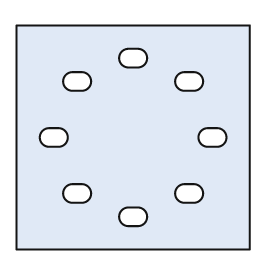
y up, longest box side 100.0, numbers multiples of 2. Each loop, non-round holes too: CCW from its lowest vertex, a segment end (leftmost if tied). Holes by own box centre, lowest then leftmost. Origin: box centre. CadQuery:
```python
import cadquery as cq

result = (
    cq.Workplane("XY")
    .moveTo(-50.0, -48.0)
    .lineTo(50.0, -48.0)
    .lineTo(50.0, 48.0)
    .lineTo(-50.0, 48.0)
    .close()
    .moveTo(-2.0, -38.0)
    .lineTo(2.0, -38.0)
    .threePointArc((6.0, -34.0), (2.0, -30.0))
    .lineTo(-2.0, -30.0)
    .threePointArc((-6.0, -34.0), (-2.0, -38.0))
    .close()
    .moveTo(-26.0, -28.0)
    .lineTo(-22.0, -28.0)
    .threePointArc((-18.0, -24.0), (-22.0, -20.0))
    .lineTo(-26.0, -20.0)
    .threePointArc((-30.0, -24.0), (-26.0, -28.0))
    .close()
    .moveTo(22.0, -28.0)
    .lineTo(26.0, -28.0)
    .threePointArc((30.0, -24.0), (26.0, -20.0))
    .lineTo(22.0, -20.0)
    .threePointArc((18.0, -24.0), (22.0, -28.0))
    .close()
    .moveTo(-36.0, -4.0)
    .lineTo(-32.0, -4.0)
    .threePointArc((-28.0, 0.0), (-32.0, 4.0))
    .lineTo(-36.0, 4.0)
    .threePointArc((-40.0, 0.0), (-36.0, -4.0))
    .close()
    .moveTo(32.0, -4.0)
    .lineTo(36.0, -4.0)
    .threePointArc((40.0, 0.0), (36.0, 4.0))
    .lineTo(32.0, 4.0)
    .threePointArc((28.0, 0.0), (32.0, -4.0))
    .close()
    .moveTo(-26.0, 20.0)
    .lineTo(-22.0, 20.0)
    .threePointArc((-18.0, 24.0), (-22.0, 28.0))
    .lineTo(-26.0, 28.0)
    .threePointArc((-30.0, 24.0), (-26.0, 20.0))
    .close()
    .moveTo(22.0, 20.0)
    .lineTo(26.0, 20.0)
    .threePointArc((30.0, 24.0), (26.0, 28.0))
    .lineTo(22.0, 28.0)
    .threePointArc((18.0, 24.0), (22.0, 20.0))
    .close()
    .moveTo(-2.0, 30.0)
    .lineTo(2.0, 30.0)
    .threePointArc((6.0, 34.0), (2.0, 38.0))
    .lineTo(-2.0, 38.0)
    .threePointArc((-6.0, 34.0), (-2.0, 30.0))
    .close()
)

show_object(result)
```